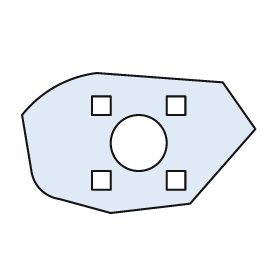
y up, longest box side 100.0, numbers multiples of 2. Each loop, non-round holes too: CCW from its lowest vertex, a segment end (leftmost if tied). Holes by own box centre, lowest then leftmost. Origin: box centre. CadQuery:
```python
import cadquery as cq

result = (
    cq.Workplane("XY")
    .moveTo(-12.0, -30.0)
    .lineTo(22.0, -26.0)
    .lineTo(50.0, 6.0)
    .lineTo(36.0, 26.0)
    .lineTo(-18.0, 30.0)
    .threePointArc((-36.0, 24.0), (-50.0, 12.0))
    .lineTo(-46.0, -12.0)
    .threePointArc((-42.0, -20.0), (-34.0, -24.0))
    .close()
    .moveTo(-20.0, -20.0)
    .lineTo(-12.0, -20.0)
    .lineTo(-12.0, -12.0)
    .lineTo(-20.0, -12.0)
    .close()
    .moveTo(12.0, -20.0)
    .lineTo(20.0, -20.0)
    .lineTo(20.0, -12.0)
    .lineTo(12.0, -12.0)
    .close()
    .moveTo(0.0, 0.0)
    .circle(12.0)
    .moveTo(-20.0, 12.0)
    .lineTo(-12.0, 12.0)
    .lineTo(-12.0, 20.0)
    .lineTo(-20.0, 20.0)
    .close()
    .moveTo(12.0, 12.0)
    .lineTo(20.0, 12.0)
    .lineTo(20.0, 20.0)
    .lineTo(12.0, 20.0)
    .close()
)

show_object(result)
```